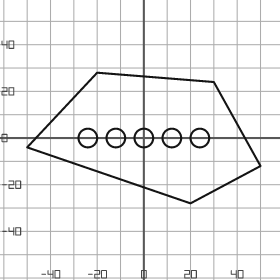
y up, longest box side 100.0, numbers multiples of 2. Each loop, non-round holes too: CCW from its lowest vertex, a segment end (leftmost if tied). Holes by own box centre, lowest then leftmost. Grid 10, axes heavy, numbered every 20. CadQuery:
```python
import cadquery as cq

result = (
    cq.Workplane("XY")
    .moveTo(20.0, -28.0)
    .lineTo(50.0, -12.0)
    .lineTo(30.0, 24.0)
    .lineTo(-20.0, 28.0)
    .lineTo(-50.0, -4.0)
    .close()
    .moveTo(-24.0, 0.0)
    .circle(4.0)
    .moveTo(-12.0, 0.0)
    .circle(4.0)
    .moveTo(0.0, 0.0)
    .circle(4.0)
    .moveTo(12.0, 0.0)
    .circle(4.0)
    .moveTo(24.0, 0.0)
    .circle(4.0)
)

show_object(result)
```